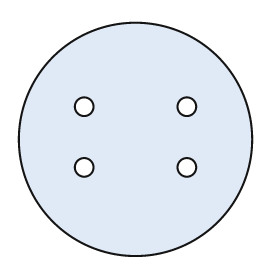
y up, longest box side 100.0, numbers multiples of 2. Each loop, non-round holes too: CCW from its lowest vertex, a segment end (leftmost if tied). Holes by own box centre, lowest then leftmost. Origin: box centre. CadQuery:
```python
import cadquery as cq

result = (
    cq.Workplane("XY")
    .moveTo(0.0, 0.0)
    .circle(50.0)
    .moveTo(-22.0, -12.0)
    .circle(4.0)
    .moveTo(22.0, -12.0)
    .circle(4.0)
    .moveTo(-22.0, 14.0)
    .circle(4.0)
    .moveTo(22.0, 14.0)
    .circle(4.0)
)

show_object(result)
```